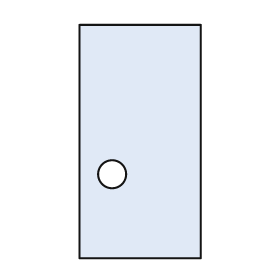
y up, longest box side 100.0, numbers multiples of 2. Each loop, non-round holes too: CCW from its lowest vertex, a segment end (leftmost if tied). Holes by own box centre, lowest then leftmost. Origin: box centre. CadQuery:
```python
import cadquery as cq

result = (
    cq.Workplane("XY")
    .moveTo(-26.0, -50.0)
    .lineTo(26.0, -50.0)
    .lineTo(26.0, 50.0)
    .lineTo(-26.0, 50.0)
    .close()
    .moveTo(-12.0, -14.0)
    .circle(6.0)
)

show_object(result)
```